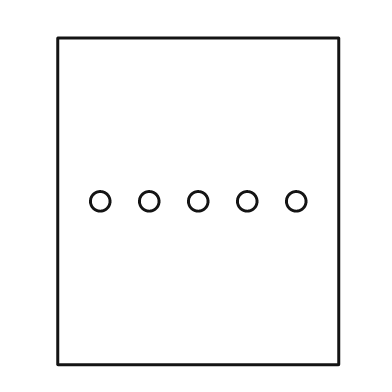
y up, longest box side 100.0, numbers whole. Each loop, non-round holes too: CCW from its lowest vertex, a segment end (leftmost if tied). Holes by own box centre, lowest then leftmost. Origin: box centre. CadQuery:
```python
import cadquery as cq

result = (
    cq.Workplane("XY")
    .moveTo(-43.0, -50.0)
    .lineTo(43.0, -50.0)
    .lineTo(43.0, 50.0)
    .lineTo(-43.0, 50.0)
    .close()
    .moveTo(-30.0, 0.0)
    .circle(3.0)
    .moveTo(-15.0, 0.0)
    .circle(3.0)
    .moveTo(0.0, 0.0)
    .circle(3.0)
    .moveTo(15.0, 0.0)
    .circle(3.0)
    .moveTo(30.0, 0.0)
    .circle(3.0)
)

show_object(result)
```